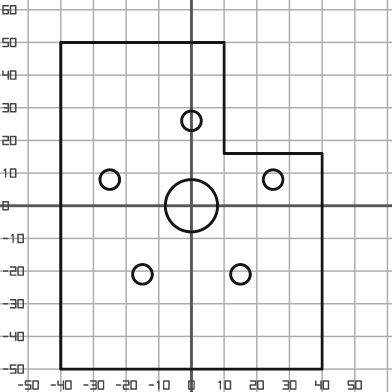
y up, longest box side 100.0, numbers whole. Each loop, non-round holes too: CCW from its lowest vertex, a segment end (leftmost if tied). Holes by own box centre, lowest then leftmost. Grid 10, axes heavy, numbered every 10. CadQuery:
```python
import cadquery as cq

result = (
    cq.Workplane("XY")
    .moveTo(-40.0, -50.0)
    .lineTo(40.0, -50.0)
    .lineTo(40.0, 16.0)
    .lineTo(10.0, 16.0)
    .lineTo(10.0, 50.0)
    .lineTo(-40.0, 50.0)
    .close()
    .moveTo(-15.0, -21.0)
    .circle(3.0)
    .moveTo(15.0, -21.0)
    .circle(3.0)
    .moveTo(0.0, 0.0)
    .circle(8.0)
    .moveTo(-25.0, 8.0)
    .circle(3.0)
    .moveTo(25.0, 8.0)
    .circle(3.0)
    .moveTo(0.0, 26.0)
    .circle(3.0)
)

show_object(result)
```